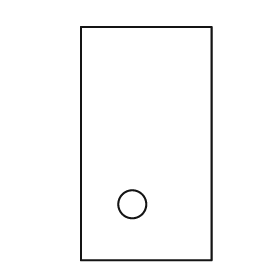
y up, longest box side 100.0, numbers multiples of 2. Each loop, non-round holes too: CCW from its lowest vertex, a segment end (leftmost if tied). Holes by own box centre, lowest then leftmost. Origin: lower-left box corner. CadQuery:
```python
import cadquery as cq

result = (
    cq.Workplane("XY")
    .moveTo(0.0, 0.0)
    .lineTo(56.0, 0.0)
    .lineTo(56.0, 100.0)
    .lineTo(0.0, 100.0)
    .close()
    .moveTo(22.0, 24.0)
    .circle(6.0)
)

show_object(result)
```